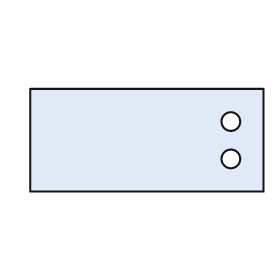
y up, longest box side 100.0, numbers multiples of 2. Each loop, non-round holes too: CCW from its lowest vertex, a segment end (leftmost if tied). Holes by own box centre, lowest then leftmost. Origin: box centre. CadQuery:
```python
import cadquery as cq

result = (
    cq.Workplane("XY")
    .moveTo(-50.0, -22.0)
    .lineTo(50.0, -22.0)
    .lineTo(50.0, 22.0)
    .lineTo(-50.0, 22.0)
    .close()
    .moveTo(36.0, -8.0)
    .circle(4.0)
    .moveTo(36.0, 8.0)
    .circle(4.0)
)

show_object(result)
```